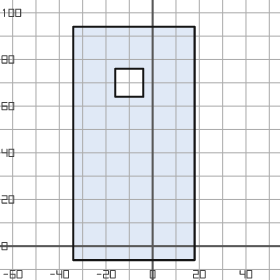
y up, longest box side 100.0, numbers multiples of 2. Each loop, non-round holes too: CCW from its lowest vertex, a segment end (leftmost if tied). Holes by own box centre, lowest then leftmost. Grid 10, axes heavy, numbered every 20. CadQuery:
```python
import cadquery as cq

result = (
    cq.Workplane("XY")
    .moveTo(-34.0, -6.0)
    .lineTo(18.0, -6.0)
    .lineTo(18.0, 94.0)
    .lineTo(-34.0, 94.0)
    .close()
    .moveTo(-16.0, 64.0)
    .lineTo(-4.0, 64.0)
    .lineTo(-4.0, 76.0)
    .lineTo(-16.0, 76.0)
    .close()
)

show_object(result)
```